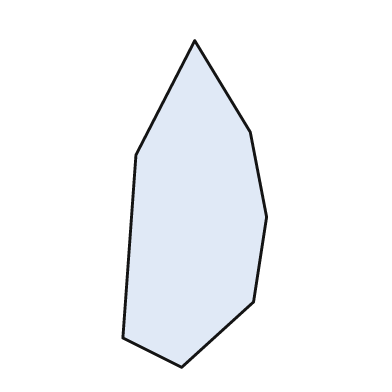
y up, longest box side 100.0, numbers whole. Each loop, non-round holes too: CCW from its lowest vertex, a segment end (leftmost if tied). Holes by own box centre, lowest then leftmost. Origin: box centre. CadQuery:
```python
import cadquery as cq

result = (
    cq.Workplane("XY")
    .moveTo(-4.0, -50.0)
    .lineTo(18.0, -30.0)
    .lineTo(22.0, -4.0)
    .lineTo(17.0, 22.0)
    .lineTo(0.0, 50.0)
    .lineTo(-18.0, 15.0)
    .lineTo(-22.0, -41.0)
    .close()
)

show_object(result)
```